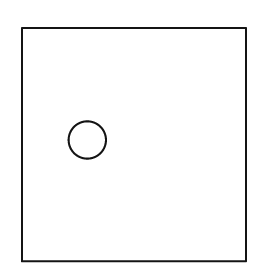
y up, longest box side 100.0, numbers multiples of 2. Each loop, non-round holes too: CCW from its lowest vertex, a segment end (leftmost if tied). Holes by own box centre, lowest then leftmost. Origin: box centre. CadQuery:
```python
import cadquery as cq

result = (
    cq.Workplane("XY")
    .moveTo(-48.0, -50.0)
    .lineTo(48.0, -50.0)
    .lineTo(48.0, 50.0)
    .lineTo(-48.0, 50.0)
    .close()
    .moveTo(-20.0, 2.0)
    .circle(8.0)
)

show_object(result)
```